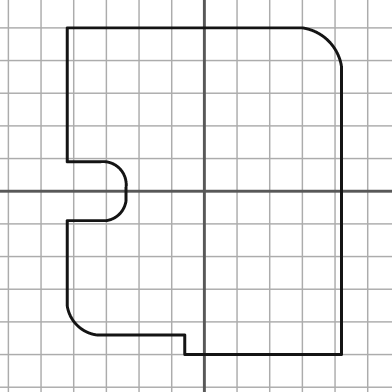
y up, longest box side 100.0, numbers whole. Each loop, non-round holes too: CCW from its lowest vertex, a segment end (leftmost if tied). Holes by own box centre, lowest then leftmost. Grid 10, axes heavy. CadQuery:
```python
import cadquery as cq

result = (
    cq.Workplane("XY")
    .moveTo(-6.0, -50.0)
    .lineTo(42.0, -50.0)
    .lineTo(42.0, 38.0)
    .threePointArc((38.0, 46.0), (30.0, 50.0))
    .lineTo(-42.0, 50.0)
    .lineTo(-42.0, 9.0)
    .lineTo(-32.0, 9.0)
    .threePointArc((-26.0, 7.0), (-24.0, 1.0))
    .lineTo(-24.0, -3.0)
    .threePointArc((-26.0, -7.0), (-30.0, -9.0))
    .lineTo(-42.0, -9.0)
    .lineTo(-42.0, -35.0)
    .threePointArc((-39.0, -41.0), (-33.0, -44.0))
    .lineTo(-6.0, -44.0)
    .close()
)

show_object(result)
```